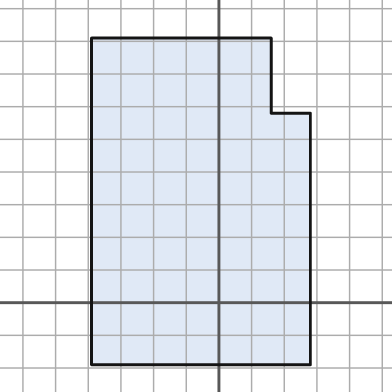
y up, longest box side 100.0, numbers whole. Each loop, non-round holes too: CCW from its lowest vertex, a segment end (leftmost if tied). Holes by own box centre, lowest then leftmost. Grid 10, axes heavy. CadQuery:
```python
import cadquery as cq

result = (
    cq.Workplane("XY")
    .moveTo(-39.0, -19.0)
    .lineTo(28.0, -19.0)
    .lineTo(28.0, 58.0)
    .lineTo(16.0, 58.0)
    .lineTo(16.0, 81.0)
    .lineTo(-39.0, 81.0)
    .close()
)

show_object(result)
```